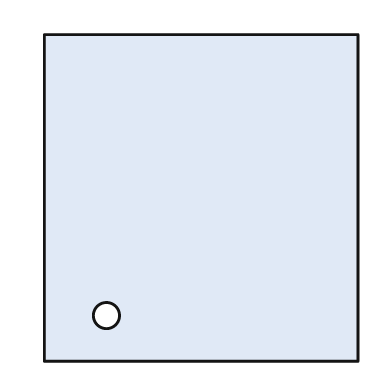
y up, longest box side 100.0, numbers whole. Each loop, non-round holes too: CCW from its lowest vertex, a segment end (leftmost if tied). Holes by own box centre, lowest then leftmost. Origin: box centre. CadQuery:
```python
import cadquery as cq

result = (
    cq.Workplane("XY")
    .moveTo(-48.0, -50.0)
    .lineTo(48.0, -50.0)
    .lineTo(48.0, 50.0)
    .lineTo(-48.0, 50.0)
    .close()
    .moveTo(-29.0, -36.0)
    .circle(4.0)
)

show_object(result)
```